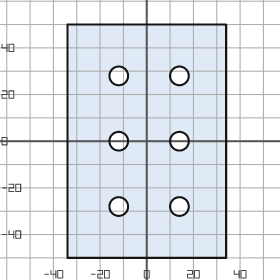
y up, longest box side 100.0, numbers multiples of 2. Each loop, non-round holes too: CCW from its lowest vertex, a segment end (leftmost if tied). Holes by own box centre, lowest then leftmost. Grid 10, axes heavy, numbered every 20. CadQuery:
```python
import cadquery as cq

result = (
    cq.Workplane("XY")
    .moveTo(-34.0, -50.0)
    .lineTo(34.0, -50.0)
    .lineTo(34.0, 50.0)
    .lineTo(-34.0, 50.0)
    .close()
    .moveTo(-12.0, -28.0)
    .circle(4.0)
    .moveTo(14.0, -28.0)
    .circle(4.0)
    .moveTo(-12.0, 0.0)
    .circle(4.0)
    .moveTo(14.0, 0.0)
    .circle(4.0)
    .moveTo(-12.0, 28.0)
    .circle(4.0)
    .moveTo(14.0, 28.0)
    .circle(4.0)
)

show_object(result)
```